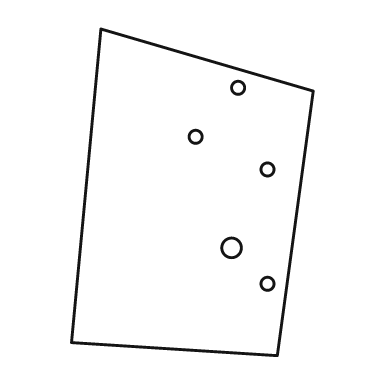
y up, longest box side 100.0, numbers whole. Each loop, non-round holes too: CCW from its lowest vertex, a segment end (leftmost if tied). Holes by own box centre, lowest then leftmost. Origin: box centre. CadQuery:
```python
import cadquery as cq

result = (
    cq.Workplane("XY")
    .moveTo(26.0, -50.0)
    .lineTo(37.0, 31.0)
    .lineTo(-28.0, 50.0)
    .lineTo(-37.0, -46.0)
    .close()
    .moveTo(23.0, -28.0)
    .circle(2.0)
    .moveTo(12.0, -17.0)
    .circle(3.0)
    .moveTo(23.0, 7.0)
    .circle(2.0)
    .moveTo(1.0, 17.0)
    .circle(2.0)
    .moveTo(14.0, 32.0)
    .circle(2.0)
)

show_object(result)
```